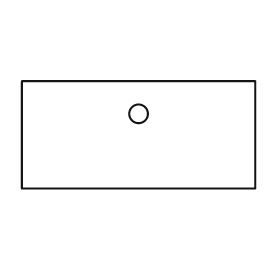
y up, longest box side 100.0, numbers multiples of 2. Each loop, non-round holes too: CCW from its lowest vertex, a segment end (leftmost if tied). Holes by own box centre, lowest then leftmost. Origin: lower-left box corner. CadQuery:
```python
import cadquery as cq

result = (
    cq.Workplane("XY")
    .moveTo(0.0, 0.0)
    .lineTo(100.0, 0.0)
    .lineTo(100.0, 46.0)
    .lineTo(0.0, 46.0)
    .close()
    .moveTo(50.0, 32.0)
    .circle(4.0)
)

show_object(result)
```